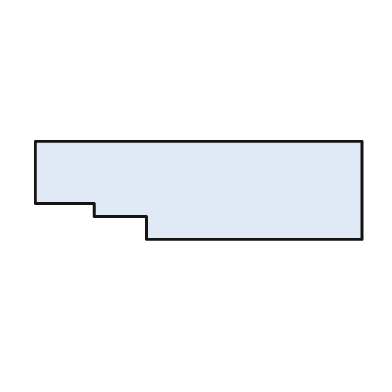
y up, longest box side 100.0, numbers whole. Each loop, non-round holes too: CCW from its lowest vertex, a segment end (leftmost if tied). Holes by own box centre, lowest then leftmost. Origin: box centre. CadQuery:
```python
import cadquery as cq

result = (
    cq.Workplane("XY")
    .moveTo(-16.0, -15.0)
    .lineTo(50.0, -15.0)
    .lineTo(50.0, 15.0)
    .lineTo(-50.0, 15.0)
    .lineTo(-50.0, -4.0)
    .lineTo(-32.0, -4.0)
    .lineTo(-32.0, -8.0)
    .lineTo(-16.0, -8.0)
    .close()
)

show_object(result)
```